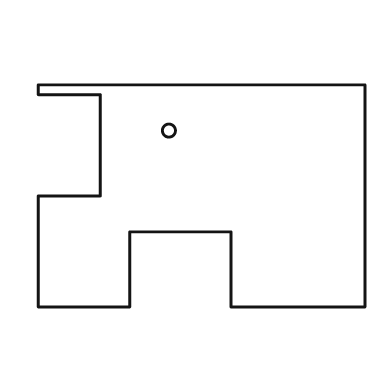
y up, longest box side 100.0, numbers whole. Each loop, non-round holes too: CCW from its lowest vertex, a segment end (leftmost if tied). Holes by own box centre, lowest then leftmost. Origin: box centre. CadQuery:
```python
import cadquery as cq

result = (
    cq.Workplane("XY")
    .moveTo(-50.0, -34.0)
    .lineTo(-22.0, -34.0)
    .lineTo(-22.0, -11.0)
    .lineTo(9.0, -11.0)
    .lineTo(9.0, -34.0)
    .lineTo(50.0, -34.0)
    .lineTo(50.0, 34.0)
    .lineTo(-50.0, 34.0)
    .lineTo(-50.0, 31.0)
    .lineTo(-31.0, 31.0)
    .lineTo(-31.0, 0.0)
    .lineTo(-50.0, 0.0)
    .close()
    .moveTo(-10.0, 20.0)
    .circle(2.0)
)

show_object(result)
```